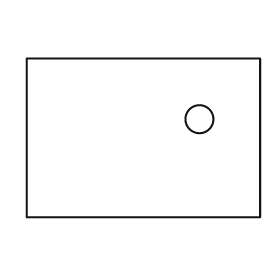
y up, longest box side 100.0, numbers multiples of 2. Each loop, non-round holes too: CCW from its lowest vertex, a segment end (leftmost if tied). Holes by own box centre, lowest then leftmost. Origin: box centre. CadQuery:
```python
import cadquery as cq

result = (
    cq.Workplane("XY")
    .moveTo(-50.0, -34.0)
    .lineTo(50.0, -34.0)
    .lineTo(50.0, 34.0)
    .lineTo(-50.0, 34.0)
    .close()
    .moveTo(24.0, 8.0)
    .circle(6.0)
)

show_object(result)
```